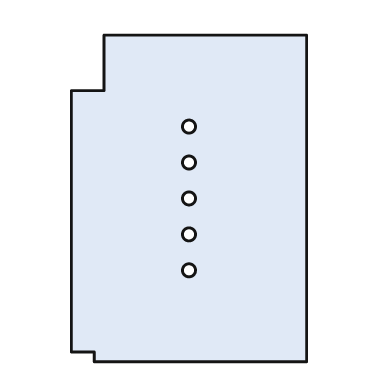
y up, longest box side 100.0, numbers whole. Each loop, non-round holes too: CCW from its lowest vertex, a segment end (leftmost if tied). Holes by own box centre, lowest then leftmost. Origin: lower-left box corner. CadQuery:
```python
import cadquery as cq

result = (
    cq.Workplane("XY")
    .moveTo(7.0, 0.0)
    .lineTo(72.0, 0.0)
    .lineTo(72.0, 100.0)
    .lineTo(10.0, 100.0)
    .lineTo(10.0, 83.0)
    .lineTo(0.0, 83.0)
    .lineTo(0.0, 3.0)
    .lineTo(7.0, 3.0)
    .close()
    .moveTo(36.0, 28.0)
    .circle(2.0)
    .moveTo(36.0, 39.0)
    .circle(2.0)
    .moveTo(36.0, 50.0)
    .circle(2.0)
    .moveTo(36.0, 61.0)
    .circle(2.0)
    .moveTo(36.0, 72.0)
    .circle(2.0)
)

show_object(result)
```